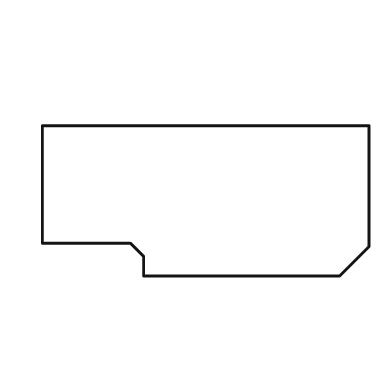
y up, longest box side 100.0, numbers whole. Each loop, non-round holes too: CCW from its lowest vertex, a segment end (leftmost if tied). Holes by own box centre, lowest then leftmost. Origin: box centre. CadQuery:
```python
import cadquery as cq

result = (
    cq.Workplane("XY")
    .moveTo(-19.0, -23.0)
    .lineTo(41.0, -23.0)
    .lineTo(50.0, -14.0)
    .lineTo(50.0, 23.0)
    .lineTo(-50.0, 23.0)
    .lineTo(-50.0, -13.0)
    .lineTo(-23.0, -13.0)
    .lineTo(-19.0, -17.0)
    .close()
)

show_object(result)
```